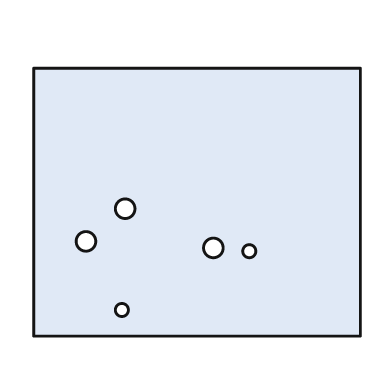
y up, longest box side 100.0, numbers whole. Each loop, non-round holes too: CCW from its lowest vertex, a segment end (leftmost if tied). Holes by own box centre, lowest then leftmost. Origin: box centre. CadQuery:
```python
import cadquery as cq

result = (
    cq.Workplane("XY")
    .moveTo(-50.0, -41.0)
    .lineTo(50.0, -41.0)
    .lineTo(50.0, 41.0)
    .lineTo(-50.0, 41.0)
    .close()
    .moveTo(-23.0, -33.0)
    .circle(2.0)
    .moveTo(16.0, -15.0)
    .circle(2.0)
    .moveTo(5.0, -14.0)
    .circle(3.0)
    .moveTo(-34.0, -12.0)
    .circle(3.0)
    .moveTo(-22.0, -2.0)
    .circle(3.0)
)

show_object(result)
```